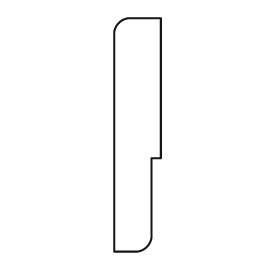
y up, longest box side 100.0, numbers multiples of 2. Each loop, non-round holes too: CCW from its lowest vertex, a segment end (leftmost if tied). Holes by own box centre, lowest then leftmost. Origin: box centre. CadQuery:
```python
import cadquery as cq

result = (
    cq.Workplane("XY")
    .moveTo(-10.0, -50.0)
    .lineTo(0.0, -50.0)
    .threePointArc((4.0, -48.0), (6.0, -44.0))
    .lineTo(6.0, -10.0)
    .lineTo(10.0, -10.0)
    .lineTo(10.0, 50.0)
    .lineTo(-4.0, 50.0)
    .threePointArc((-8.0, 48.0), (-10.0, 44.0))
    .close()
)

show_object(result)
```